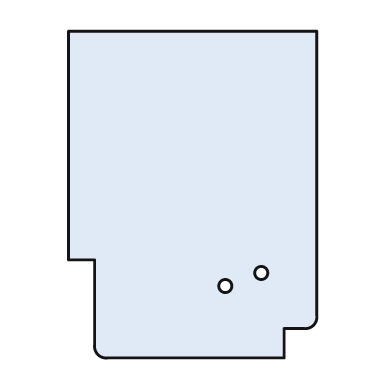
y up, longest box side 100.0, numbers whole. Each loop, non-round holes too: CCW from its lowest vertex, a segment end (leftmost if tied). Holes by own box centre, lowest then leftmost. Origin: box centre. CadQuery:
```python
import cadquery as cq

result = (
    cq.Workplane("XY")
    .moveTo(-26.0, -50.0)
    .lineTo(28.0, -50.0)
    .lineTo(28.0, -41.0)
    .lineTo(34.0, -41.0)
    .threePointArc((37.0, -40.0), (38.0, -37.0))
    .lineTo(38.0, 50.0)
    .lineTo(-38.0, 50.0)
    .lineTo(-38.0, -20.0)
    .lineTo(-30.0, -20.0)
    .lineTo(-30.0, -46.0)
    .threePointArc((-29.0, -49.0), (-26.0, -50.0))
    .close()
    .moveTo(10.0, -28.0)
    .circle(2.0)
    .moveTo(21.0, -24.0)
    .circle(2.0)
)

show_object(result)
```